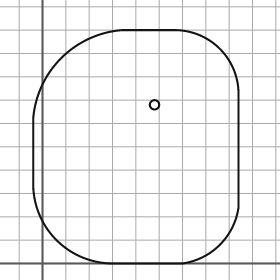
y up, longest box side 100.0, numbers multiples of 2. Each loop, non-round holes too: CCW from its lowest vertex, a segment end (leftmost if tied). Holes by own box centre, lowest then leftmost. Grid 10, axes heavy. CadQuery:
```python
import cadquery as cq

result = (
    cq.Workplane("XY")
    .moveTo(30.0, 0.0)
    .lineTo(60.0, 0.0)
    .threePointArc((76.0, 8.0), (84.0, 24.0))
    .lineTo(84.0, 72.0)
    .threePointArc((76.0, 92.0), (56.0, 100.0))
    .lineTo(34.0, 100.0)
    .threePointArc((8.0, 88.0), (-4.0, 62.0))
    .lineTo(-4.0, 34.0)
    .threePointArc((6.0, 10.0), (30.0, 0.0))
    .close()
    .moveTo(48.0, 68.0)
    .circle(2.0)
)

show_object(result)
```